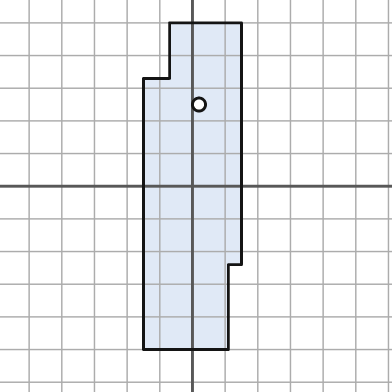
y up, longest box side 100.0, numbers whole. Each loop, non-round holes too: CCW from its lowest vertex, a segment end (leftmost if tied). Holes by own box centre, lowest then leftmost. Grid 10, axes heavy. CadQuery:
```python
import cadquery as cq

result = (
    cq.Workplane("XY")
    .moveTo(-15.0, -50.0)
    .lineTo(11.0, -50.0)
    .lineTo(11.0, -24.0)
    .lineTo(15.0, -24.0)
    .lineTo(15.0, 50.0)
    .lineTo(-7.0, 50.0)
    .lineTo(-7.0, 33.0)
    .lineTo(-15.0, 33.0)
    .close()
    .moveTo(2.0, 25.0)
    .circle(2.0)
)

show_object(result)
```